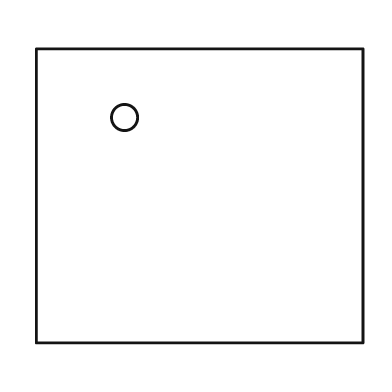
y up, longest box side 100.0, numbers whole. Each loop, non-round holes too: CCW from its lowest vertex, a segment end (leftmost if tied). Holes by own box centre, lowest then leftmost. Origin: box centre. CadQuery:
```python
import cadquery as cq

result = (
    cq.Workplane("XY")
    .moveTo(-50.0, -45.0)
    .lineTo(50.0, -45.0)
    .lineTo(50.0, 45.0)
    .lineTo(-50.0, 45.0)
    .close()
    .moveTo(-23.0, 24.0)
    .circle(4.0)
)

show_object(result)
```